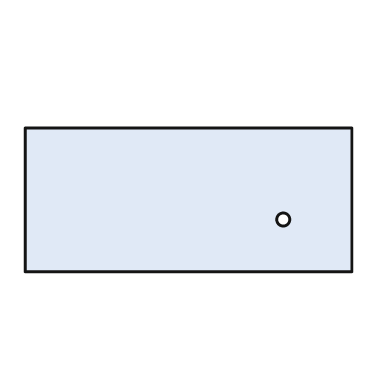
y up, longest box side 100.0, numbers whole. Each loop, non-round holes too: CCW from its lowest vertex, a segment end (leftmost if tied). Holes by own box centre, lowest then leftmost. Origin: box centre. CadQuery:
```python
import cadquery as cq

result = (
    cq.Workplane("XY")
    .moveTo(-50.0, -22.0)
    .lineTo(50.0, -22.0)
    .lineTo(50.0, 22.0)
    .lineTo(-50.0, 22.0)
    .close()
    .moveTo(29.0, -6.0)
    .circle(2.0)
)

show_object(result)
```